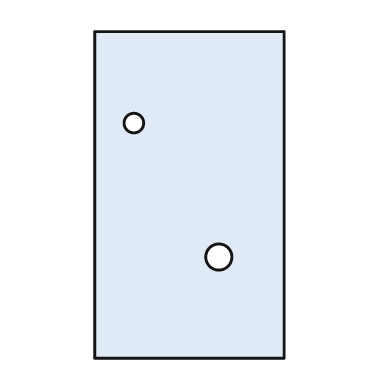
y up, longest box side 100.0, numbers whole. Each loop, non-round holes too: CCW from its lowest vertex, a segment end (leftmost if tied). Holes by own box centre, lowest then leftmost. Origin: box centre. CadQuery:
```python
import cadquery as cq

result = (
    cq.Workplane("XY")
    .moveTo(-29.0, -50.0)
    .lineTo(29.0, -50.0)
    .lineTo(29.0, 50.0)
    .lineTo(-29.0, 50.0)
    .close()
    .moveTo(9.0, -19.0)
    .circle(4.0)
    .moveTo(-17.0, 22.0)
    .circle(3.0)
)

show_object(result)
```